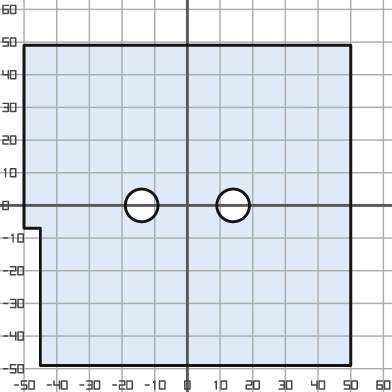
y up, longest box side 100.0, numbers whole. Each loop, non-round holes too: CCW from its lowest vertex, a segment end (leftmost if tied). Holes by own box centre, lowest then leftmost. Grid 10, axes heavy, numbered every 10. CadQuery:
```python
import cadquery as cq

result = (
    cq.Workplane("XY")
    .moveTo(-45.0, -49.0)
    .lineTo(50.0, -49.0)
    .lineTo(50.0, 49.0)
    .lineTo(-50.0, 49.0)
    .lineTo(-50.0, -7.0)
    .lineTo(-45.0, -7.0)
    .close()
    .moveTo(-14.0, 0.0)
    .circle(5.0)
    .moveTo(14.0, 0.0)
    .circle(5.0)
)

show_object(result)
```